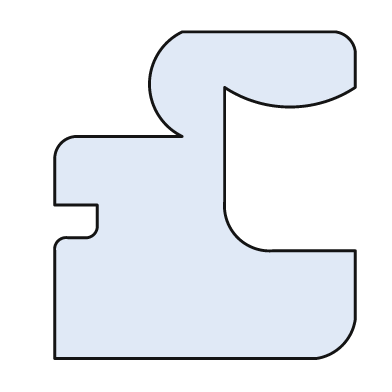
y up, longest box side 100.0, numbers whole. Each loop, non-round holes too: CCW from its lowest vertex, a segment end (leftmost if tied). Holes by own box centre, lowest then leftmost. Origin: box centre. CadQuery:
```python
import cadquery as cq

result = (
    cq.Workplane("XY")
    .moveTo(-46.0, -50.0)
    .lineTo(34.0, -50.0)
    .threePointArc((42.0, -46.0), (46.0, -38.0))
    .lineTo(46.0, -17.0)
    .lineTo(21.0, -17.0)
    .threePointArc((10.0, -13.0), (6.0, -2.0))
    .lineTo(6.0, 33.0)
    .threePointArc((26.0, 27.0), (46.0, 33.0))
    .lineTo(46.0, 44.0)
    .threePointArc((44.0, 48.0), (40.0, 50.0))
    .lineTo(-7.0, 50.0)
    .threePointArc((-17.0, 34.0), (-7.0, 18.0))
    .lineTo(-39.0, 18.0)
    .threePointArc((-44.0, 16.0), (-46.0, 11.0))
    .lineTo(-46.0, -3.0)
    .lineTo(-33.0, -3.0)
    .lineTo(-33.0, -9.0)
    .threePointArc((-34.0, -12.0), (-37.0, -13.0))
    .lineTo(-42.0, -13.0)
    .threePointArc((-45.0, -14.0), (-46.0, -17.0))
    .close()
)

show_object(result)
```